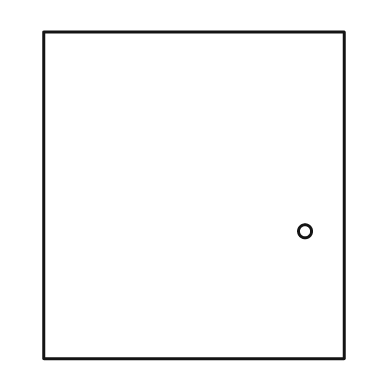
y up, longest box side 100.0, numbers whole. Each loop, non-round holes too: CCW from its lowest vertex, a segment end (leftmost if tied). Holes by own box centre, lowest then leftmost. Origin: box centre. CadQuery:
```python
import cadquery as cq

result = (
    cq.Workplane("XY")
    .moveTo(-46.0, -50.0)
    .lineTo(46.0, -50.0)
    .lineTo(46.0, 50.0)
    .lineTo(-46.0, 50.0)
    .close()
    .moveTo(34.0, -11.0)
    .circle(2.0)
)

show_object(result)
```